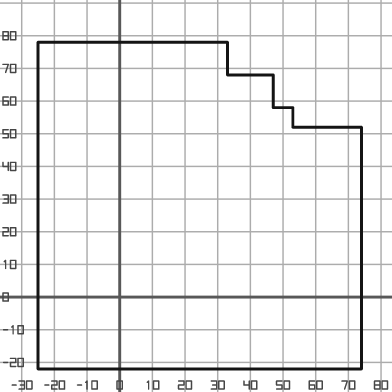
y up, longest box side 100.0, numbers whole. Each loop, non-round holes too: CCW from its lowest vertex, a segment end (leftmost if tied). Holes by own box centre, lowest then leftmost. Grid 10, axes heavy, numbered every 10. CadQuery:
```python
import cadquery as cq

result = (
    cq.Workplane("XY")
    .moveTo(-25.0, -22.0)
    .lineTo(74.0, -22.0)
    .lineTo(74.0, 52.0)
    .lineTo(53.0, 52.0)
    .lineTo(53.0, 58.0)
    .lineTo(47.0, 58.0)
    .lineTo(47.0, 68.0)
    .lineTo(33.0, 68.0)
    .lineTo(33.0, 78.0)
    .lineTo(-25.0, 78.0)
    .close()
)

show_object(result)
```